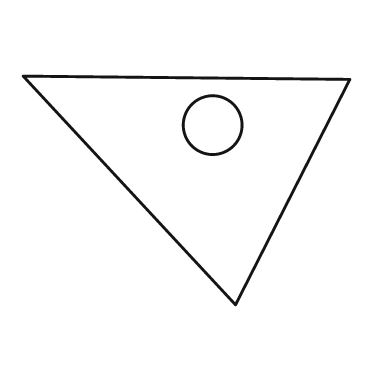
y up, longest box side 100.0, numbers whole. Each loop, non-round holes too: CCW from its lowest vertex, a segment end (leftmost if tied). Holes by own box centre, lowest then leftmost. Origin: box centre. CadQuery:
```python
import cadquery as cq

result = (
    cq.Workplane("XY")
    .moveTo(15.0, -35.0)
    .lineTo(50.0, 34.0)
    .lineTo(-50.0, 35.0)
    .close()
    .moveTo(8.0, 20.0)
    .circle(9.0)
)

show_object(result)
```